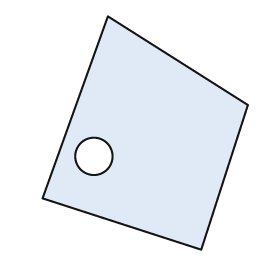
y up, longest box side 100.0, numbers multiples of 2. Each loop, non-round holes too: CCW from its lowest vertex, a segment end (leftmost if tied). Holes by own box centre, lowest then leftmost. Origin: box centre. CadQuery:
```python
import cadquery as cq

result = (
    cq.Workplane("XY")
    .moveTo(24.0, -50.0)
    .lineTo(44.0, 12.0)
    .lineTo(-16.0, 50.0)
    .lineTo(-44.0, -28.0)
    .close()
    .moveTo(-22.0, -10.0)
    .circle(8.0)
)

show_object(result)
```